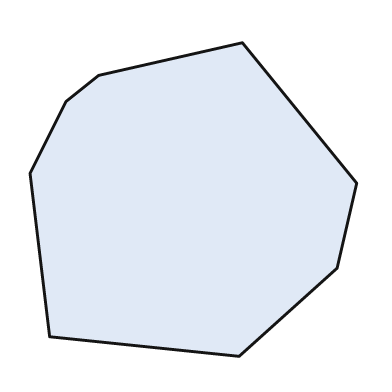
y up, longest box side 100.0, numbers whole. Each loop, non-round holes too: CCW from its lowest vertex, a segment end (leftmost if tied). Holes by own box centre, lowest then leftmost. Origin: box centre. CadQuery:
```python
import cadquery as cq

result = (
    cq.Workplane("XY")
    .moveTo(14.0, -48.0)
    .lineTo(44.0, -21.0)
    .lineTo(50.0, 5.0)
    .lineTo(15.0, 48.0)
    .lineTo(-29.0, 38.0)
    .lineTo(-39.0, 30.0)
    .lineTo(-50.0, 8.0)
    .lineTo(-44.0, -42.0)
    .close()
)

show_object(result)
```